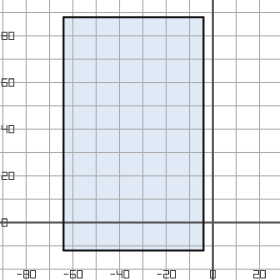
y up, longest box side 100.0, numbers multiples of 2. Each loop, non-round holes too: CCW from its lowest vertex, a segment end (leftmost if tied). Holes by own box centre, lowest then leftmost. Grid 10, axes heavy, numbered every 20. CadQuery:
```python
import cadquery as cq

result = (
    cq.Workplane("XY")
    .moveTo(-64.0, -12.0)
    .lineTo(-4.0, -12.0)
    .lineTo(-4.0, 88.0)
    .lineTo(-64.0, 88.0)
    .close()
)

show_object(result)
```